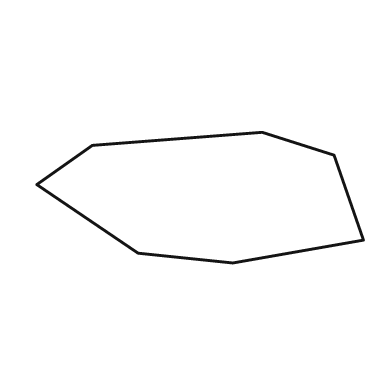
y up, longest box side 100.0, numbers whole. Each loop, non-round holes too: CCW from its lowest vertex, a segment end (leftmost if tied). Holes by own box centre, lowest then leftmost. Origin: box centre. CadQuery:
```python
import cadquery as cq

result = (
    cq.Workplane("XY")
    .moveTo(10.0, -20.0)
    .lineTo(50.0, -13.0)
    .lineTo(41.0, 13.0)
    .lineTo(19.0, 20.0)
    .lineTo(-33.0, 16.0)
    .lineTo(-50.0, 4.0)
    .lineTo(-19.0, -17.0)
    .close()
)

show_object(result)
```